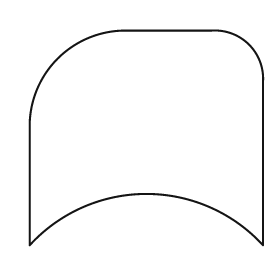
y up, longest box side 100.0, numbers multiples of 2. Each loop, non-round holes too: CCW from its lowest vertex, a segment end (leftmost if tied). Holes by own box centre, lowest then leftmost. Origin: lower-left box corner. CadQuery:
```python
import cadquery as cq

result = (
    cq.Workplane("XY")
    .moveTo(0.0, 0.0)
    .threePointArc((50.0, 22.0), (100.0, 0.0))
    .lineTo(100.0, 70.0)
    .threePointArc((94.0, 86.0), (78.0, 92.0))
    .lineTo(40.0, 92.0)
    .threePointArc((12.0, 80.0), (0.0, 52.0))
    .close()
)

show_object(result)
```